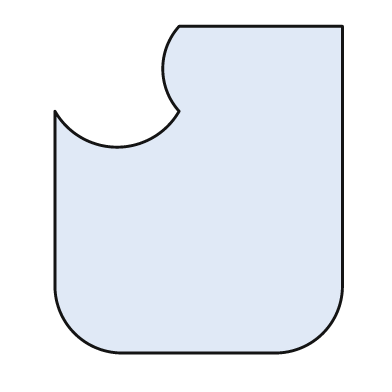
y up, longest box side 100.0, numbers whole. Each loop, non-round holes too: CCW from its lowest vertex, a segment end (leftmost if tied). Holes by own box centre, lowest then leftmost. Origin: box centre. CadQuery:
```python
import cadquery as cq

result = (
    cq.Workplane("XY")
    .moveTo(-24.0, -50.0)
    .lineTo(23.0, -50.0)
    .threePointArc((38.0, -44.0), (44.0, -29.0))
    .lineTo(44.0, 50.0)
    .lineTo(-6.0, 50.0)
    .threePointArc((-11.0, 37.0), (-6.0, 24.0))
    .threePointArc((-25.0, 13.0), (-44.0, 24.0))
    .lineTo(-44.0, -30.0)
    .threePointArc((-38.0, -44.0), (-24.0, -50.0))
    .close()
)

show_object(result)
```